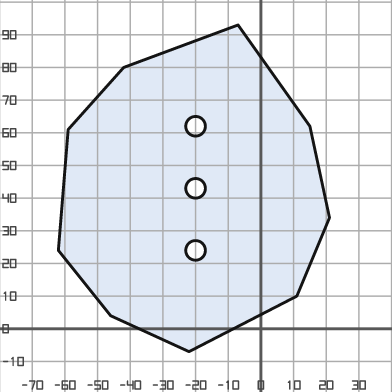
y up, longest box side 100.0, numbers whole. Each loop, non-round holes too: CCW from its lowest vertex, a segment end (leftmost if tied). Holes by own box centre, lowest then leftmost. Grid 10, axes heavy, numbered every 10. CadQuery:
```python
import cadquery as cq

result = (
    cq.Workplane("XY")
    .moveTo(-22.0, -7.0)
    .lineTo(11.0, 10.0)
    .lineTo(21.0, 34.0)
    .lineTo(15.0, 62.0)
    .lineTo(-7.0, 93.0)
    .lineTo(-42.0, 80.0)
    .lineTo(-59.0, 61.0)
    .lineTo(-62.0, 24.0)
    .lineTo(-46.0, 4.0)
    .close()
    .moveTo(-20.0, 24.0)
    .circle(3.0)
    .moveTo(-20.0, 43.0)
    .circle(3.0)
    .moveTo(-20.0, 62.0)
    .circle(3.0)
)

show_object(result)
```